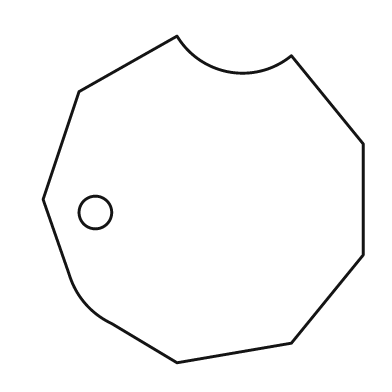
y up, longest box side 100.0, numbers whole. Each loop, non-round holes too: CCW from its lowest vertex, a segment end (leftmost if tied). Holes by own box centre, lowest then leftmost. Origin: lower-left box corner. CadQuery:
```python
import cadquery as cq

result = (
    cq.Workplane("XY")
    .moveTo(41.0, 0.0)
    .lineTo(76.0, 6.0)
    .lineTo(98.0, 33.0)
    .lineTo(98.0, 67.0)
    .lineTo(76.0, 94.0)
    .threePointArc((57.0, 89.0), (41.0, 100.0))
    .lineTo(11.0, 83.0)
    .lineTo(0.0, 50.0)
    .lineTo(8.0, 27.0)
    .threePointArc((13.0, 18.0), (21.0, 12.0))
    .close()
    .moveTo(16.0, 46.0)
    .circle(5.0)
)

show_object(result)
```